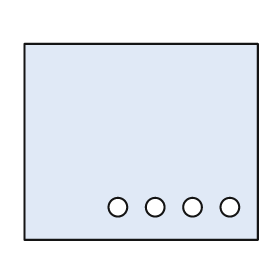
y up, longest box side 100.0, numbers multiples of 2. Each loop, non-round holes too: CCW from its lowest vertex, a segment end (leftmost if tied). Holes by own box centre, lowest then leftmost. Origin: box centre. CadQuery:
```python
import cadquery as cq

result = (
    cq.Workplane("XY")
    .moveTo(-50.0, -42.0)
    .lineTo(50.0, -42.0)
    .lineTo(50.0, 42.0)
    .lineTo(-50.0, 42.0)
    .close()
    .moveTo(-10.0, -28.0)
    .circle(4.0)
    .moveTo(6.0, -28.0)
    .circle(4.0)
    .moveTo(22.0, -28.0)
    .circle(4.0)
    .moveTo(38.0, -28.0)
    .circle(4.0)
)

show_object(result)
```